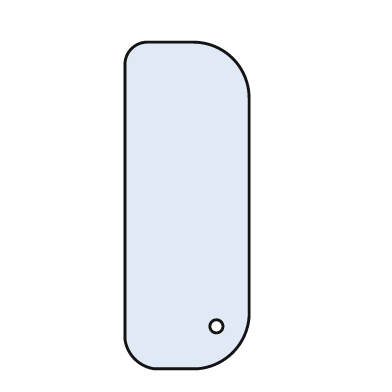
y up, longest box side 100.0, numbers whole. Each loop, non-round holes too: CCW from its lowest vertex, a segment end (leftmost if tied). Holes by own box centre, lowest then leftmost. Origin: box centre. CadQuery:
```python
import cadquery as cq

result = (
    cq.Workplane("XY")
    .moveTo(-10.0, -50.0)
    .lineTo(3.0, -50.0)
    .threePointArc((14.0, -45.0), (19.0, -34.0))
    .lineTo(19.0, 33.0)
    .threePointArc((14.0, 45.0), (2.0, 50.0))
    .lineTo(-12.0, 50.0)
    .threePointArc((-17.0, 48.0), (-19.0, 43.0))
    .lineTo(-19.0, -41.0)
    .threePointArc((-16.0, -47.0), (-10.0, -50.0))
    .close()
    .moveTo(9.0, -37.0)
    .circle(2.0)
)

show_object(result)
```